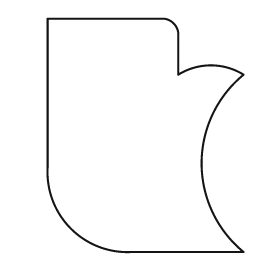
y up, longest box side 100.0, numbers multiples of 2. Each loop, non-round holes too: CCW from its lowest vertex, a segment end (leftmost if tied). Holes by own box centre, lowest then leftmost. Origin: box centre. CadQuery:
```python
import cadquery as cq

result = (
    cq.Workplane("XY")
    .moveTo(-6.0, -50.0)
    .lineTo(42.0, -50.0)
    .threePointArc((24.0, -12.0), (42.0, 26.0))
    .threePointArc((28.0, 30.0), (14.0, 26.0))
    .lineTo(14.0, 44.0)
    .threePointArc((12.0, 48.0), (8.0, 50.0))
    .lineTo(-42.0, 50.0)
    .lineTo(-42.0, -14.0)
    .threePointArc((-32.0, -40.0), (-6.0, -50.0))
    .close()
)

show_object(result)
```